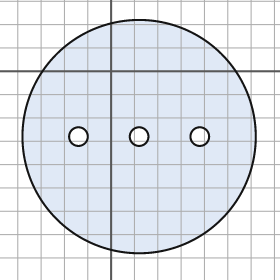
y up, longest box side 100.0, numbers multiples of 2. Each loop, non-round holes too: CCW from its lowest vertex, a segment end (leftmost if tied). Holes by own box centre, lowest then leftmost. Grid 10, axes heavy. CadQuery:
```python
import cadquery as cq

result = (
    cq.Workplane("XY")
    .moveTo(12.0, -28.0)
    .circle(50.0)
    .moveTo(-14.0, -28.0)
    .circle(4.0)
    .moveTo(12.0, -28.0)
    .circle(4.0)
    .moveTo(38.0, -28.0)
    .circle(4.0)
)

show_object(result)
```